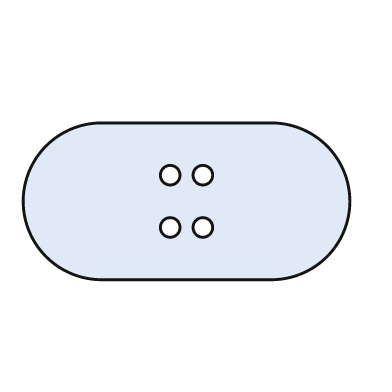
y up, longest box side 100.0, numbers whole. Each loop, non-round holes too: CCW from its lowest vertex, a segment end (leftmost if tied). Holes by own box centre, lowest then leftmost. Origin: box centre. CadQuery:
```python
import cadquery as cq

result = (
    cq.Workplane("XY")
    .moveTo(-26.0, -24.0)
    .lineTo(26.0, -24.0)
    .threePointArc((50.0, 0.0), (26.0, 24.0))
    .lineTo(-26.0, 24.0)
    .threePointArc((-50.0, 0.0), (-26.0, -24.0))
    .close()
    .moveTo(-5.0, -8.0)
    .circle(3.0)
    .moveTo(5.0, -8.0)
    .circle(3.0)
    .moveTo(-5.0, 8.0)
    .circle(3.0)
    .moveTo(5.0, 8.0)
    .circle(3.0)
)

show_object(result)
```